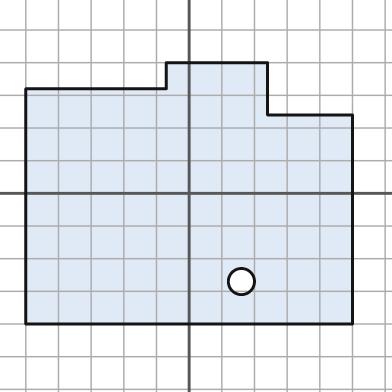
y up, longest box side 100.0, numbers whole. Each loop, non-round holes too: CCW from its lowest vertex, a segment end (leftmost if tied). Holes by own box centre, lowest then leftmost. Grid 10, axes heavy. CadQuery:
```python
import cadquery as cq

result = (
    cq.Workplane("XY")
    .moveTo(-50.0, -40.0)
    .lineTo(50.0, -40.0)
    .lineTo(50.0, 24.0)
    .lineTo(24.0, 24.0)
    .lineTo(24.0, 40.0)
    .lineTo(-7.0, 40.0)
    .lineTo(-7.0, 32.0)
    .lineTo(-50.0, 32.0)
    .close()
    .moveTo(16.0, -27.0)
    .circle(4.0)
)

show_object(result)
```